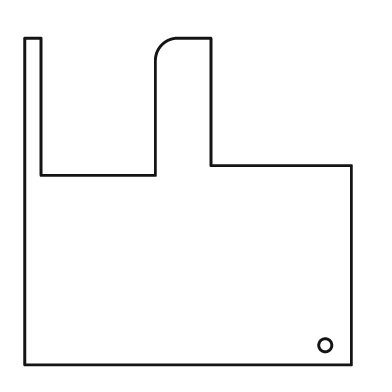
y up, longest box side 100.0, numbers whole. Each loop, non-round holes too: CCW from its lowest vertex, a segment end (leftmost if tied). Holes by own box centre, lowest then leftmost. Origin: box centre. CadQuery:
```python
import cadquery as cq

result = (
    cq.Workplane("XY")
    .moveTo(-50.0, -50.0)
    .lineTo(50.0, -50.0)
    .lineTo(50.0, 11.0)
    .lineTo(7.0, 11.0)
    .lineTo(7.0, 50.0)
    .lineTo(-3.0, 50.0)
    .threePointArc((-8.0, 48.0), (-10.0, 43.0))
    .lineTo(-10.0, 8.0)
    .lineTo(-45.0, 8.0)
    .lineTo(-45.0, 50.0)
    .lineTo(-50.0, 50.0)
    .close()
    .moveTo(42.0, -44.0)
    .circle(2.0)
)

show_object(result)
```